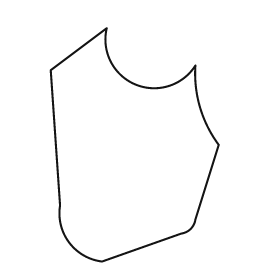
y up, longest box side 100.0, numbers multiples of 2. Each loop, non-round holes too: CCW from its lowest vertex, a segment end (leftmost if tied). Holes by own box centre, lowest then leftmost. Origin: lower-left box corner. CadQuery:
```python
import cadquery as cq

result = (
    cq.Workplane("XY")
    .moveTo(22.0, 0.0)
    .lineTo(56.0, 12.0)
    .threePointArc((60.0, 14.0), (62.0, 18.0))
    .lineTo(72.0, 50.0)
    .threePointArc((64.0, 66.0), (62.0, 84.0))
    .threePointArc((36.0, 76.0), (24.0, 100.0))
    .lineTo(0.0, 82.0)
    .lineTo(4.0, 24.0)
    .threePointArc((8.0, 8.0), (22.0, 0.0))
    .close()
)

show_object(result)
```